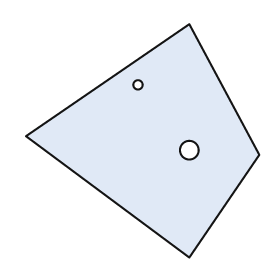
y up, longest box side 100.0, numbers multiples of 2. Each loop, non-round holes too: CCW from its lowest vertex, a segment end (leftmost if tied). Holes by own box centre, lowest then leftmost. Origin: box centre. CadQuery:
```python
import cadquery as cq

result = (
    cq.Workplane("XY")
    .moveTo(20.0, -50.0)
    .lineTo(50.0, -6.0)
    .lineTo(20.0, 50.0)
    .lineTo(-50.0, 2.0)
    .close()
    .moveTo(20.0, -4.0)
    .circle(4.0)
    .moveTo(-2.0, 24.0)
    .circle(2.0)
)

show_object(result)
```